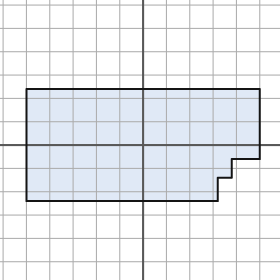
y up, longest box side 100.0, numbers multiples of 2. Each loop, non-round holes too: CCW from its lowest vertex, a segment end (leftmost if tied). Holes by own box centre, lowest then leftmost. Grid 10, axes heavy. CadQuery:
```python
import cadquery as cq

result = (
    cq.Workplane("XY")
    .moveTo(-50.0, -24.0)
    .lineTo(32.0, -24.0)
    .lineTo(32.0, -14.0)
    .lineTo(38.0, -14.0)
    .lineTo(38.0, -6.0)
    .lineTo(50.0, -6.0)
    .lineTo(50.0, 24.0)
    .lineTo(-50.0, 24.0)
    .close()
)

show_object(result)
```